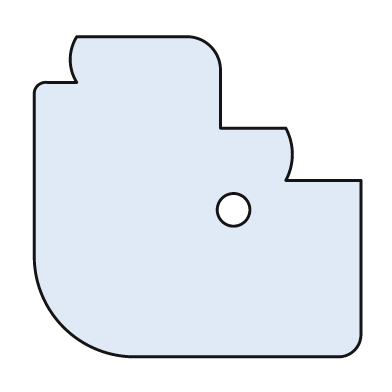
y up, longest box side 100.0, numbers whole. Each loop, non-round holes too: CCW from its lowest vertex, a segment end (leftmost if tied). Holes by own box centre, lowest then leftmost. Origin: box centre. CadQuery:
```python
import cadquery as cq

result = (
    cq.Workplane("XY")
    .moveTo(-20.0, -49.0)
    .lineTo(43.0, -49.0)
    .threePointArc((48.0, -47.0), (50.0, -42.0))
    .lineTo(50.0, 5.0)
    .lineTo(27.0, 5.0)
    .threePointArc((29.0, 13.0), (27.0, 21.0))
    .lineTo(7.0, 21.0)
    .lineTo(7.0, 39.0)
    .threePointArc((4.0, 46.0), (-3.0, 49.0))
    .lineTo(-37.0, 49.0)
    .threePointArc((-39.0, 42.0), (-37.0, 35.0))
    .lineTo(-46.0, 35.0)
    .threePointArc((-49.0, 34.0), (-50.0, 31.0))
    .lineTo(-50.0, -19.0)
    .threePointArc((-41.0, -40.0), (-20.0, -49.0))
    .close()
    .moveTo(11.0, -4.0)
    .circle(5.0)
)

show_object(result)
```